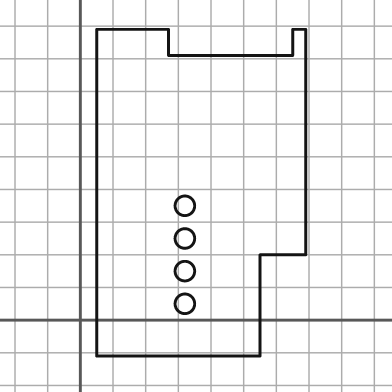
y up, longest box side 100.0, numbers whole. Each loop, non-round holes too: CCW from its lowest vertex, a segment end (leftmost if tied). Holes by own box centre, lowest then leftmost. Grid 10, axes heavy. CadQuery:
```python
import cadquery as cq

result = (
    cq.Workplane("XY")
    .moveTo(5.0, -11.0)
    .lineTo(55.0, -11.0)
    .lineTo(55.0, 20.0)
    .lineTo(69.0, 20.0)
    .lineTo(69.0, 89.0)
    .lineTo(65.0, 89.0)
    .lineTo(65.0, 81.0)
    .lineTo(27.0, 81.0)
    .lineTo(27.0, 89.0)
    .lineTo(5.0, 89.0)
    .close()
    .moveTo(32.0, 5.0)
    .circle(3.0)
    .moveTo(32.0, 15.0)
    .circle(3.0)
    .moveTo(32.0, 25.0)
    .circle(3.0)
    .moveTo(32.0, 35.0)
    .circle(3.0)
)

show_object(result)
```